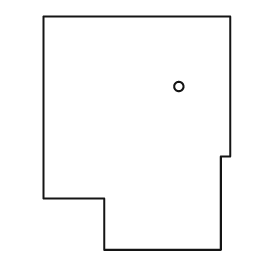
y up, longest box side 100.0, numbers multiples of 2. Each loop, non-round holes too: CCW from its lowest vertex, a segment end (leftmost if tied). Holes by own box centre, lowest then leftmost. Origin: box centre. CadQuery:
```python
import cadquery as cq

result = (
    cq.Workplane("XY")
    .moveTo(-14.0, -50.0)
    .lineTo(36.0, -50.0)
    .lineTo(36.0, -10.0)
    .lineTo(40.0, -10.0)
    .lineTo(40.0, 50.0)
    .lineTo(-40.0, 50.0)
    .lineTo(-40.0, -28.0)
    .lineTo(-14.0, -28.0)
    .close()
    .moveTo(18.0, 20.0)
    .circle(2.0)
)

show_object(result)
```